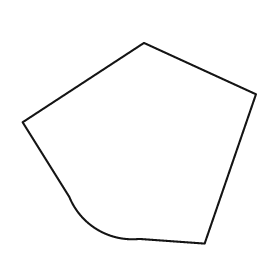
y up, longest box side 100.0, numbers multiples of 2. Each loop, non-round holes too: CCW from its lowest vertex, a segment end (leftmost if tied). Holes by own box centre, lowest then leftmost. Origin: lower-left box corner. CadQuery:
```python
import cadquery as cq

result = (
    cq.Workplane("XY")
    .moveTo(78.0, 0.0)
    .lineTo(100.0, 64.0)
    .lineTo(52.0, 86.0)
    .lineTo(0.0, 52.0)
    .lineTo(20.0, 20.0)
    .threePointArc((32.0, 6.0), (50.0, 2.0))
    .close()
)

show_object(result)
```